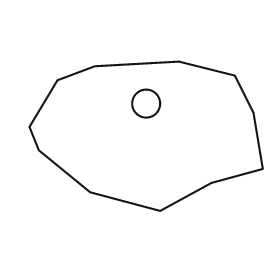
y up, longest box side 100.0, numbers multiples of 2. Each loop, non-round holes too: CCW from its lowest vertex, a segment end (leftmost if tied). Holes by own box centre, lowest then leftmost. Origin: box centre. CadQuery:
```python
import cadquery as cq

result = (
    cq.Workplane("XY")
    .moveTo(6.0, -32.0)
    .lineTo(28.0, -20.0)
    .lineTo(50.0, -14.0)
    .lineTo(46.0, 10.0)
    .lineTo(38.0, 26.0)
    .lineTo(14.0, 32.0)
    .lineTo(-22.0, 30.0)
    .lineTo(-38.0, 24.0)
    .lineTo(-50.0, 4.0)
    .lineTo(-46.0, -6.0)
    .lineTo(-24.0, -24.0)
    .close()
    .moveTo(0.0, 14.0)
    .circle(6.0)
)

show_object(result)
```